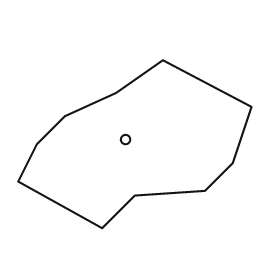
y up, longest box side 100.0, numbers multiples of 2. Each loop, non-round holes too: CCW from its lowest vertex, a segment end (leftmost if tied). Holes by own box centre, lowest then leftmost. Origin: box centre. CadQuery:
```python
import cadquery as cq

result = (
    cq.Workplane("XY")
    .moveTo(-14.0, -36.0)
    .lineTo(0.0, -22.0)
    .lineTo(30.0, -20.0)
    .lineTo(42.0, -8.0)
    .lineTo(50.0, 16.0)
    .lineTo(12.0, 36.0)
    .lineTo(-8.0, 22.0)
    .lineTo(-30.0, 12.0)
    .lineTo(-42.0, 0.0)
    .lineTo(-50.0, -16.0)
    .close()
    .moveTo(-4.0, 2.0)
    .circle(2.0)
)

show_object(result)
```